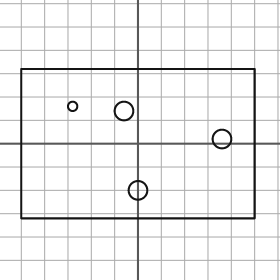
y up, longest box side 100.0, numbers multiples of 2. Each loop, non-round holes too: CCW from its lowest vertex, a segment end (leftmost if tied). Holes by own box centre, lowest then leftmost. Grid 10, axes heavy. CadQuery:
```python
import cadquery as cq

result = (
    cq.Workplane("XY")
    .moveTo(-50.0, -32.0)
    .lineTo(50.0, -32.0)
    .lineTo(50.0, 32.0)
    .lineTo(-50.0, 32.0)
    .close()
    .moveTo(0.0, -20.0)
    .circle(4.0)
    .moveTo(36.0, 2.0)
    .circle(4.0)
    .moveTo(-6.0, 14.0)
    .circle(4.0)
    .moveTo(-28.0, 16.0)
    .circle(2.0)
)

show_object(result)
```